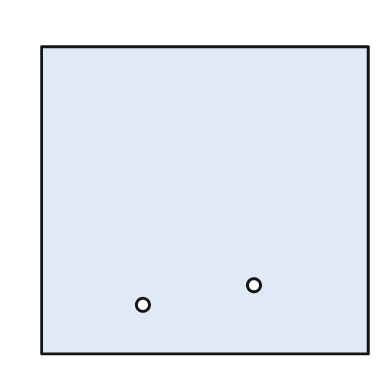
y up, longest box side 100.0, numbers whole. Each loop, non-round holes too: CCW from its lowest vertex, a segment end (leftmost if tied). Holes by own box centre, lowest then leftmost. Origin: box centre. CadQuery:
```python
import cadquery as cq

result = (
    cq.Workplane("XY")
    .moveTo(-50.0, -47.0)
    .lineTo(50.0, -47.0)
    .lineTo(50.0, 47.0)
    .lineTo(-50.0, 47.0)
    .close()
    .moveTo(-19.0, -32.0)
    .circle(2.0)
    .moveTo(15.0, -26.0)
    .circle(2.0)
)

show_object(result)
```